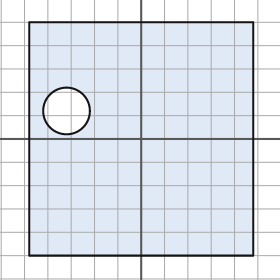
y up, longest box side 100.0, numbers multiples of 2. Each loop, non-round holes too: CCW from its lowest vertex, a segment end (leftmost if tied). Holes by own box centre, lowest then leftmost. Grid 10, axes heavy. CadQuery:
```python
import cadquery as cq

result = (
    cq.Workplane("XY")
    .moveTo(-48.0, -50.0)
    .lineTo(48.0, -50.0)
    .lineTo(48.0, 50.0)
    .lineTo(-48.0, 50.0)
    .close()
    .moveTo(-32.0, 12.0)
    .circle(10.0)
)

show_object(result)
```